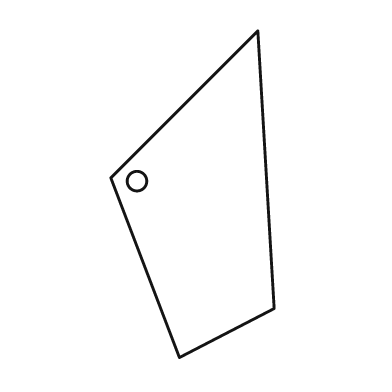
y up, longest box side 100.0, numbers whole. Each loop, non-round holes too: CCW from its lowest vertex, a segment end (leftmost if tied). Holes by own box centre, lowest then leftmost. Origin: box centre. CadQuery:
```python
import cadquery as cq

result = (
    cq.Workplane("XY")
    .moveTo(-4.0, -50.0)
    .lineTo(25.0, -35.0)
    .lineTo(20.0, 50.0)
    .lineTo(-25.0, 5.0)
    .close()
    .moveTo(-17.0, 4.0)
    .circle(3.0)
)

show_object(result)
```